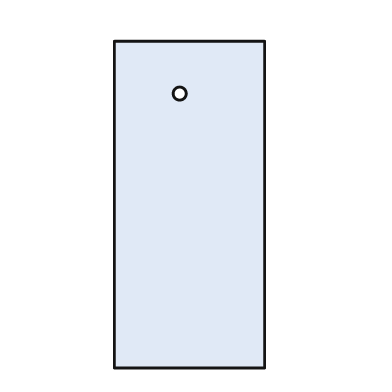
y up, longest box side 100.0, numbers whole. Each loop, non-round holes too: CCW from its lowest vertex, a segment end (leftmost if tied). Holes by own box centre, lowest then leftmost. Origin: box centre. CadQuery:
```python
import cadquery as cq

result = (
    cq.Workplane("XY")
    .moveTo(-23.0, -50.0)
    .lineTo(23.0, -50.0)
    .lineTo(23.0, 50.0)
    .lineTo(-23.0, 50.0)
    .close()
    .moveTo(-3.0, 34.0)
    .circle(2.0)
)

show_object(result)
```